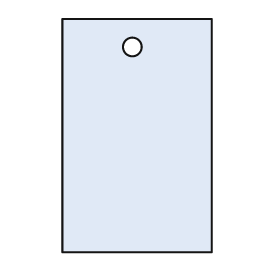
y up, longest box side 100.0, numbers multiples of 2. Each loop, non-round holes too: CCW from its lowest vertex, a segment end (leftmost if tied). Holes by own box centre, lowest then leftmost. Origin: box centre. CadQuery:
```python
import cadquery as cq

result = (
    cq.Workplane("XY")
    .moveTo(-32.0, -50.0)
    .lineTo(32.0, -50.0)
    .lineTo(32.0, 50.0)
    .lineTo(-32.0, 50.0)
    .close()
    .moveTo(-2.0, 38.0)
    .circle(4.0)
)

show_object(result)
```